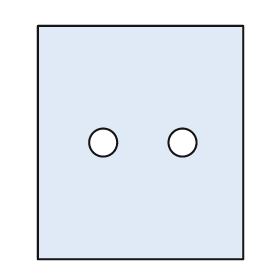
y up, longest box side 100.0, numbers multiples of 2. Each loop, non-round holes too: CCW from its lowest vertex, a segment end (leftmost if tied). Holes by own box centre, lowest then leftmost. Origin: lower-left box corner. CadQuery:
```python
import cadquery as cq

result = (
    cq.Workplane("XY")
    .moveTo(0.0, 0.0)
    .lineTo(88.0, 0.0)
    .lineTo(88.0, 100.0)
    .lineTo(0.0, 100.0)
    .close()
    .moveTo(28.0, 50.0)
    .circle(6.0)
    .moveTo(62.0, 50.0)
    .circle(6.0)
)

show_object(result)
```